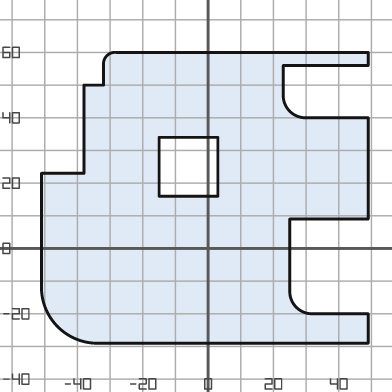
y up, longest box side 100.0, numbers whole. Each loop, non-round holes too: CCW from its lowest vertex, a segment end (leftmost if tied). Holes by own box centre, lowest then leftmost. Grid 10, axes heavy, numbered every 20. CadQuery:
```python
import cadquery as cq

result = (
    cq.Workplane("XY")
    .moveTo(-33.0, -29.0)
    .lineTo(49.0, -29.0)
    .lineTo(49.0, -20.0)
    .lineTo(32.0, -20.0)
    .threePointArc((27.0, -18.0), (25.0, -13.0))
    .lineTo(25.0, 9.0)
    .lineTo(49.0, 9.0)
    .lineTo(49.0, 40.0)
    .lineTo(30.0, 40.0)
    .threePointArc((25.0, 42.0), (23.0, 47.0))
    .lineTo(23.0, 56.0)
    .lineTo(49.0, 56.0)
    .lineTo(49.0, 60.0)
    .lineTo(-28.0, 60.0)
    .threePointArc((-31.0, 59.0), (-32.0, 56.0))
    .lineTo(-32.0, 50.0)
    .lineTo(-38.0, 50.0)
    .lineTo(-38.0, 23.0)
    .lineTo(-51.0, 23.0)
    .lineTo(-51.0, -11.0)
    .threePointArc((-46.0, -24.0), (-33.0, -29.0))
    .close()
    .moveTo(-15.0, 16.0)
    .lineTo(3.0, 16.0)
    .lineTo(3.0, 34.0)
    .lineTo(-15.0, 34.0)
    .close()
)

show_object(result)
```